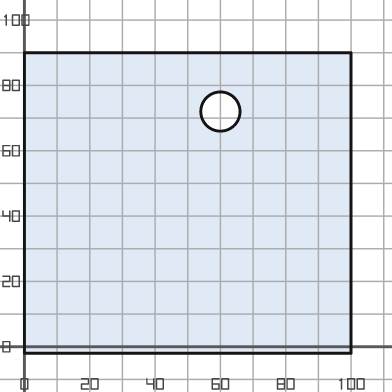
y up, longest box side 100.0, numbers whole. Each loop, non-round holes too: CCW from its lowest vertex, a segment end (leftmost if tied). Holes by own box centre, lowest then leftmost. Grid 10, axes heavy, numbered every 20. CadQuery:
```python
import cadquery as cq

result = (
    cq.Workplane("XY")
    .moveTo(0.0, -2.0)
    .lineTo(100.0, -2.0)
    .lineTo(100.0, 90.0)
    .lineTo(0.0, 90.0)
    .close()
    .moveTo(60.0, 72.0)
    .circle(6.0)
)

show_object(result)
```